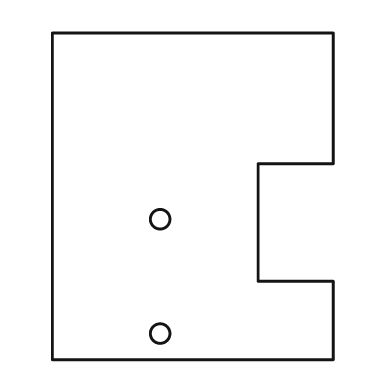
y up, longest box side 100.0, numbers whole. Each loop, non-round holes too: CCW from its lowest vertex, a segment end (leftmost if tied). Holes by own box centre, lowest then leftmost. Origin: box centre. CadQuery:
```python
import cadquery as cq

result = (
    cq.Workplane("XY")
    .moveTo(-43.0, -50.0)
    .lineTo(43.0, -50.0)
    .lineTo(43.0, -26.0)
    .lineTo(20.0, -26.0)
    .lineTo(20.0, 10.0)
    .lineTo(43.0, 10.0)
    .lineTo(43.0, 50.0)
    .lineTo(-43.0, 50.0)
    .close()
    .moveTo(-10.0, -42.0)
    .circle(3.0)
    .moveTo(-10.0, -7.0)
    .circle(3.0)
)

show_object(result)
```